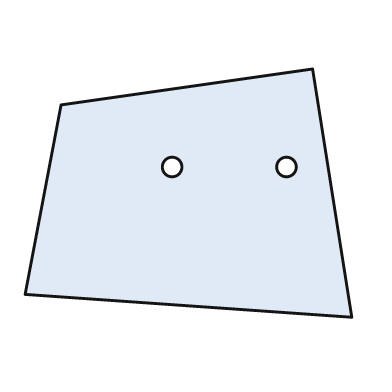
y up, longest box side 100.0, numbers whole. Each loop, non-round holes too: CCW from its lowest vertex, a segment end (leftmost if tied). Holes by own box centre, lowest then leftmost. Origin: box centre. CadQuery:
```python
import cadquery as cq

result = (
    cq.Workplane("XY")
    .moveTo(50.0, -38.0)
    .lineTo(38.0, 38.0)
    .lineTo(-39.0, 27.0)
    .lineTo(-50.0, -31.0)
    .close()
    .moveTo(-5.0, 8.0)
    .circle(3.0)
    .moveTo(30.0, 8.0)
    .circle(3.0)
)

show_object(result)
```